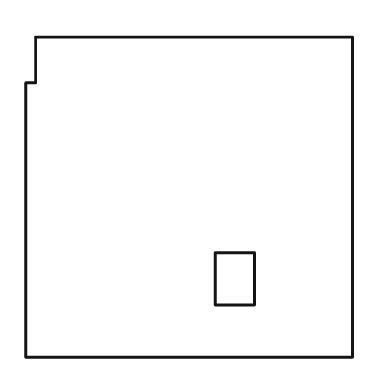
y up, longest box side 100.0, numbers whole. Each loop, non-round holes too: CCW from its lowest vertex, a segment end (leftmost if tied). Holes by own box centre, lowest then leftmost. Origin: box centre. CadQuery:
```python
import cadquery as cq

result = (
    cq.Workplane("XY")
    .moveTo(-50.0, -49.0)
    .lineTo(50.0, -49.0)
    .lineTo(50.0, 49.0)
    .lineTo(-47.0, 49.0)
    .lineTo(-47.0, 35.0)
    .lineTo(-50.0, 35.0)
    .close()
    .moveTo(8.0, -33.0)
    .lineTo(20.0, -33.0)
    .lineTo(20.0, -17.0)
    .lineTo(8.0, -17.0)
    .close()
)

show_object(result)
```